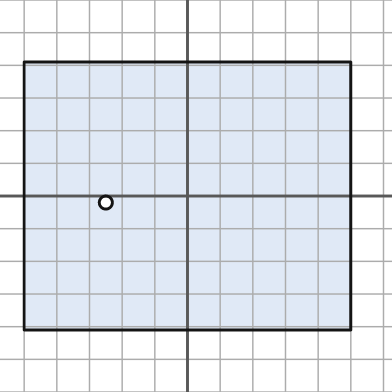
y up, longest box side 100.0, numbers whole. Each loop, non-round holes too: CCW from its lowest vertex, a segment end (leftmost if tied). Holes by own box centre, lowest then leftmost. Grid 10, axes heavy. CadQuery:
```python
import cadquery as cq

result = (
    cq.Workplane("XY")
    .moveTo(-50.0, -41.0)
    .lineTo(50.0, -41.0)
    .lineTo(50.0, 41.0)
    .lineTo(-50.0, 41.0)
    .close()
    .moveTo(-25.0, -2.0)
    .circle(2.0)
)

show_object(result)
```